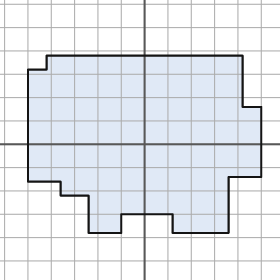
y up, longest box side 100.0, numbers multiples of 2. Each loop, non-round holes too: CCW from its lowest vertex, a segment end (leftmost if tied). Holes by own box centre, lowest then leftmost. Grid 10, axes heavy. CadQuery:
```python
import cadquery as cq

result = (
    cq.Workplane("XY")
    .moveTo(-24.0, -38.0)
    .lineTo(-10.0, -38.0)
    .lineTo(-10.0, -30.0)
    .lineTo(12.0, -30.0)
    .lineTo(12.0, -38.0)
    .lineTo(36.0, -38.0)
    .lineTo(36.0, -14.0)
    .lineTo(50.0, -14.0)
    .lineTo(50.0, 16.0)
    .lineTo(42.0, 16.0)
    .lineTo(42.0, 38.0)
    .lineTo(-42.0, 38.0)
    .lineTo(-42.0, 32.0)
    .lineTo(-50.0, 32.0)
    .lineTo(-50.0, -16.0)
    .lineTo(-36.0, -16.0)
    .lineTo(-36.0, -22.0)
    .lineTo(-24.0, -22.0)
    .close()
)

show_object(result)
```